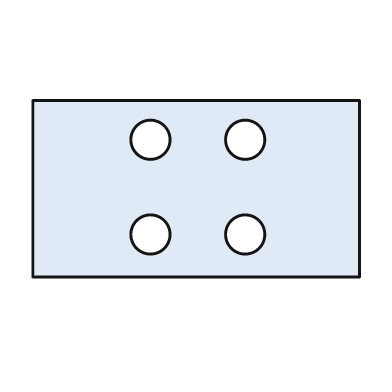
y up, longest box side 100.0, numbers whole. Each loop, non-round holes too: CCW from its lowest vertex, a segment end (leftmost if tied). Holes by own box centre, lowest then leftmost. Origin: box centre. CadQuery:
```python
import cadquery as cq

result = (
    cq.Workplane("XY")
    .moveTo(-50.0, -27.0)
    .lineTo(50.0, -27.0)
    .lineTo(50.0, 27.0)
    .lineTo(-50.0, 27.0)
    .close()
    .moveTo(-14.0, -14.0)
    .circle(6.0)
    .moveTo(15.0, -14.0)
    .circle(6.0)
    .moveTo(-14.0, 15.0)
    .circle(6.0)
    .moveTo(15.0, 15.0)
    .circle(6.0)
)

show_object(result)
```